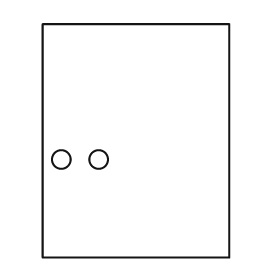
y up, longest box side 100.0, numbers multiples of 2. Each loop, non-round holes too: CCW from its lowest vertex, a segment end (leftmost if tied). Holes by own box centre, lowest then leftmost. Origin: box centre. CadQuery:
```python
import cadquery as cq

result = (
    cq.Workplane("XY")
    .moveTo(-40.0, -50.0)
    .lineTo(40.0, -50.0)
    .lineTo(40.0, 50.0)
    .lineTo(-40.0, 50.0)
    .close()
    .moveTo(-32.0, -8.0)
    .circle(4.0)
    .moveTo(-16.0, -8.0)
    .circle(4.0)
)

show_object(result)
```